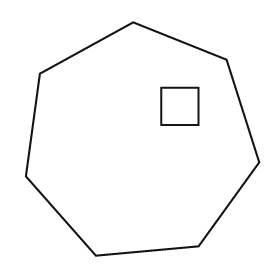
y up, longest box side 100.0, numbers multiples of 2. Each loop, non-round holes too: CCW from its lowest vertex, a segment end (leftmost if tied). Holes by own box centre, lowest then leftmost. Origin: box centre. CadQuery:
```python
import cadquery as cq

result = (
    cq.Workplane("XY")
    .moveTo(-20.0, -50.0)
    .lineTo(24.0, -46.0)
    .lineTo(50.0, -10.0)
    .lineTo(36.0, 34.0)
    .lineTo(-4.0, 50.0)
    .lineTo(-44.0, 28.0)
    .lineTo(-50.0, -16.0)
    .close()
    .moveTo(8.0, 6.0)
    .lineTo(24.0, 6.0)
    .lineTo(24.0, 22.0)
    .lineTo(8.0, 22.0)
    .close()
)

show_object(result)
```